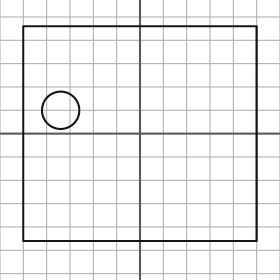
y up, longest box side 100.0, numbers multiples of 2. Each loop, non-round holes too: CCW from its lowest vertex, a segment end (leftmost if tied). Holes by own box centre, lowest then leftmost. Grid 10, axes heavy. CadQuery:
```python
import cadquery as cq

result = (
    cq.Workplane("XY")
    .moveTo(-50.0, -46.0)
    .lineTo(50.0, -46.0)
    .lineTo(50.0, 46.0)
    .lineTo(-50.0, 46.0)
    .close()
    .moveTo(-34.0, 10.0)
    .circle(8.0)
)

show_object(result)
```